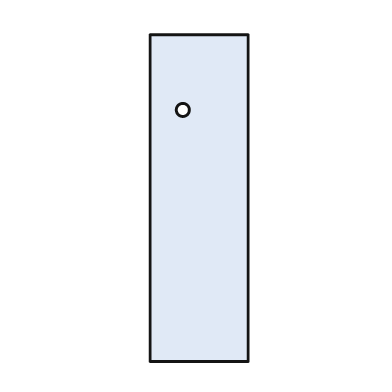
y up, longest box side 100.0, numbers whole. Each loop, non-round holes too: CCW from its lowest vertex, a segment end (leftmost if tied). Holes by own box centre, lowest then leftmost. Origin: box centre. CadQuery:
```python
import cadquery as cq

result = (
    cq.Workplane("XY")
    .moveTo(-15.0, -50.0)
    .lineTo(15.0, -50.0)
    .lineTo(15.0, 50.0)
    .lineTo(-15.0, 50.0)
    .close()
    .moveTo(-5.0, 27.0)
    .circle(2.0)
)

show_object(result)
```